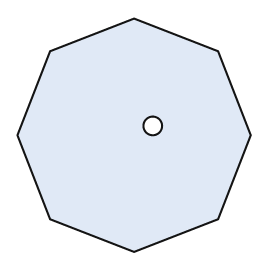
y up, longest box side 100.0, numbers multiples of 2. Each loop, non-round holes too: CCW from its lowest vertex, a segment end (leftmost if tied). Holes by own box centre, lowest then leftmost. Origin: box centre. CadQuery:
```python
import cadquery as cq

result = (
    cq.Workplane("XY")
    .moveTo(0.0, -50.0)
    .lineTo(36.0, -36.0)
    .lineTo(50.0, 0.0)
    .lineTo(36.0, 36.0)
    .lineTo(0.0, 50.0)
    .lineTo(-36.0, 36.0)
    .lineTo(-50.0, 0.0)
    .lineTo(-36.0, -36.0)
    .close()
    .moveTo(8.0, 4.0)
    .circle(4.0)
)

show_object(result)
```